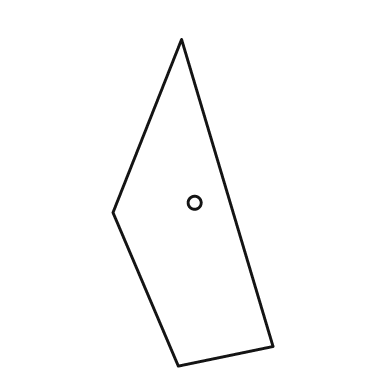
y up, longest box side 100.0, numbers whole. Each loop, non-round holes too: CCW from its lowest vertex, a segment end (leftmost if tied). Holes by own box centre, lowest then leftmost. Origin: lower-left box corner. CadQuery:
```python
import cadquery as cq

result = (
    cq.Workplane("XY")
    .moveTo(20.0, 0.0)
    .lineTo(49.0, 6.0)
    .lineTo(21.0, 100.0)
    .lineTo(0.0, 47.0)
    .close()
    .moveTo(25.0, 50.0)
    .circle(2.0)
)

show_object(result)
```